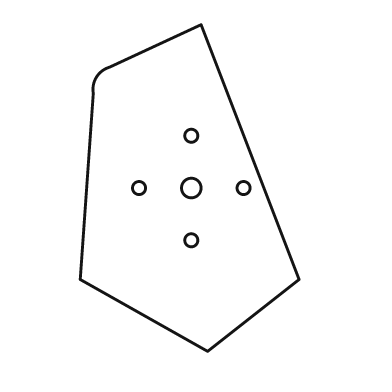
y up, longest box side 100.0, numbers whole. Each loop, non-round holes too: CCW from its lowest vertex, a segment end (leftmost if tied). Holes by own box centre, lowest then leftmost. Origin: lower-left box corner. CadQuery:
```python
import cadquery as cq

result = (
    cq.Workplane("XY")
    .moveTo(39.0, 0.0)
    .lineTo(67.0, 22.0)
    .lineTo(37.0, 100.0)
    .lineTo(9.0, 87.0)
    .threePointArc((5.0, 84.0), (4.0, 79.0))
    .lineTo(0.0, 22.0)
    .close()
    .moveTo(34.0, 34.0)
    .circle(2.0)
    .moveTo(18.0, 50.0)
    .circle(2.0)
    .moveTo(34.0, 50.0)
    .circle(3.0)
    .moveTo(50.0, 50.0)
    .circle(2.0)
    .moveTo(34.0, 66.0)
    .circle(2.0)
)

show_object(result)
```